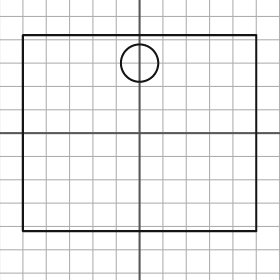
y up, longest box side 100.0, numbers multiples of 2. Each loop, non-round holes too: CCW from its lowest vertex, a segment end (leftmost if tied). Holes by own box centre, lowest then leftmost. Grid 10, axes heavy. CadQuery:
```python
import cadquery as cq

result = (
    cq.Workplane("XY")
    .moveTo(-50.0, -42.0)
    .lineTo(50.0, -42.0)
    .lineTo(50.0, 42.0)
    .lineTo(-50.0, 42.0)
    .close()
    .moveTo(0.0, 30.0)
    .circle(8.0)
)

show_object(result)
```